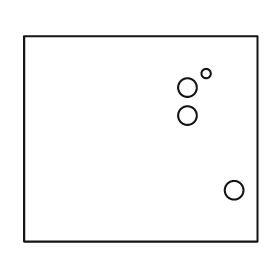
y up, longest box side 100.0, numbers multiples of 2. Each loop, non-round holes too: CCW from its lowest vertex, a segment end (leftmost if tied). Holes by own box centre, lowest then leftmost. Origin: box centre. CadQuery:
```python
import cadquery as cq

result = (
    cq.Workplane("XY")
    .moveTo(-50.0, -44.0)
    .lineTo(50.0, -44.0)
    .lineTo(50.0, 44.0)
    .lineTo(-50.0, 44.0)
    .close()
    .moveTo(40.0, -22.0)
    .circle(4.0)
    .moveTo(20.0, 10.0)
    .circle(4.0)
    .moveTo(20.0, 22.0)
    .circle(4.0)
    .moveTo(28.0, 28.0)
    .circle(2.0)
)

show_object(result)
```